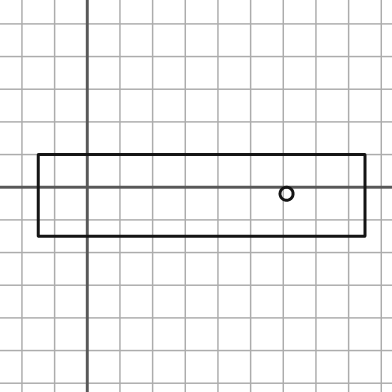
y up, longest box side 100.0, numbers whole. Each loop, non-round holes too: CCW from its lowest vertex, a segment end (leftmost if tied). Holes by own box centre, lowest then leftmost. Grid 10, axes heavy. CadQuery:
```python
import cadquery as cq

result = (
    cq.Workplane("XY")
    .moveTo(-15.0, -15.0)
    .lineTo(85.0, -15.0)
    .lineTo(85.0, 10.0)
    .lineTo(-15.0, 10.0)
    .close()
    .moveTo(61.0, -2.0)
    .circle(2.0)
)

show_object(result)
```